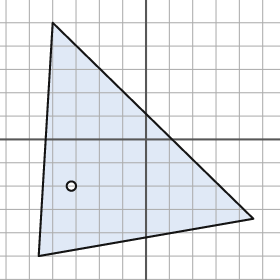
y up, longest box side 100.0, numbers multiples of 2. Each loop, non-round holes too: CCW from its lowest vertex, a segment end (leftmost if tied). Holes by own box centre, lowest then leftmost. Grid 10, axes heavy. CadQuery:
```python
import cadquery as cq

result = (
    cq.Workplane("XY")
    .moveTo(-46.0, -50.0)
    .lineTo(46.0, -34.0)
    .lineTo(-40.0, 50.0)
    .close()
    .moveTo(-32.0, -20.0)
    .circle(2.0)
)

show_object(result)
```